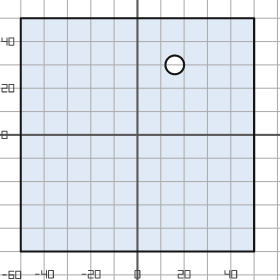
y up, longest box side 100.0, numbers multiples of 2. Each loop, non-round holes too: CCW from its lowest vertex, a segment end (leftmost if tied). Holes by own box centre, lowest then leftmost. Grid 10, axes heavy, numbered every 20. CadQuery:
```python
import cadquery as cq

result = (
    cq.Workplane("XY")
    .moveTo(-50.0, -50.0)
    .lineTo(50.0, -50.0)
    .lineTo(50.0, 50.0)
    .lineTo(-50.0, 50.0)
    .close()
    .moveTo(16.0, 30.0)
    .circle(4.0)
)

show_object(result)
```